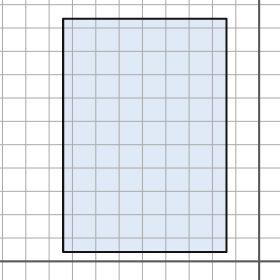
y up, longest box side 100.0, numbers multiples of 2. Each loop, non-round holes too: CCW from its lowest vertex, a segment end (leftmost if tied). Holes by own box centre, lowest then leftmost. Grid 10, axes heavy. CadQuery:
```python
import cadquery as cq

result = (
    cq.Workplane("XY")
    .moveTo(-84.0, 4.0)
    .lineTo(-14.0, 4.0)
    .lineTo(-14.0, 104.0)
    .lineTo(-84.0, 104.0)
    .close()
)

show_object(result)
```